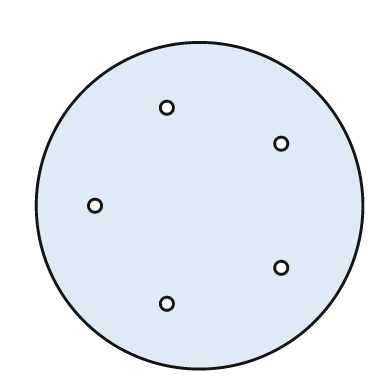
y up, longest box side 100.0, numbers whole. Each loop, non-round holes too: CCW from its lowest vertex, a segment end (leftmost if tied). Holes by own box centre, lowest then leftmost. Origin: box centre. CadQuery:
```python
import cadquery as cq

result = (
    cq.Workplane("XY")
    .moveTo(0.0, 0.0)
    .circle(50.0)
    .moveTo(-10.0, -30.0)
    .circle(2.0)
    .moveTo(25.0, -19.0)
    .circle(2.0)
    .moveTo(-32.0, 0.0)
    .circle(2.0)
    .moveTo(25.0, 19.0)
    .circle(2.0)
    .moveTo(-10.0, 30.0)
    .circle(2.0)
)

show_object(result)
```